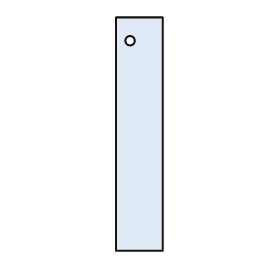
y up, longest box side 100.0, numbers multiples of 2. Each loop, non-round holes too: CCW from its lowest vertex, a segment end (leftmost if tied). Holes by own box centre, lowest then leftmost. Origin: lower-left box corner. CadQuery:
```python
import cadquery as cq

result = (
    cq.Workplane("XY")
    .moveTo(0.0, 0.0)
    .lineTo(20.0, 0.0)
    .lineTo(20.0, 100.0)
    .lineTo(0.0, 100.0)
    .close()
    .moveTo(6.0, 90.0)
    .circle(2.0)
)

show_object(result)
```